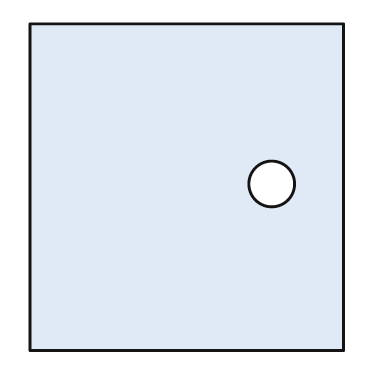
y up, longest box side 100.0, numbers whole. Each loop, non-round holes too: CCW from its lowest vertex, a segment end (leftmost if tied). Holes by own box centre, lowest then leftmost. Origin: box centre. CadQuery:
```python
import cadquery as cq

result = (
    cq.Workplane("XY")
    .moveTo(-48.0, -50.0)
    .lineTo(48.0, -50.0)
    .lineTo(48.0, 50.0)
    .lineTo(-48.0, 50.0)
    .close()
    .moveTo(26.0, 1.0)
    .circle(7.0)
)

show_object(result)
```